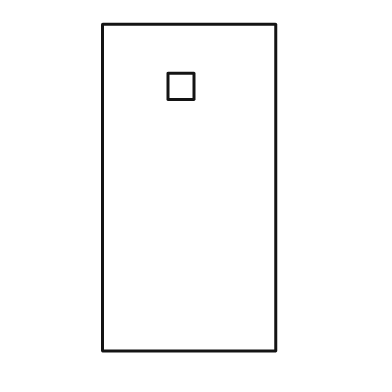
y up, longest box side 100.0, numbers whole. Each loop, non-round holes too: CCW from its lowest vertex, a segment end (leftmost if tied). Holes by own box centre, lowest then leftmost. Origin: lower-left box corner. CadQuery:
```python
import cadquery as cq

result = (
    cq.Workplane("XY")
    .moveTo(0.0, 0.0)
    .lineTo(53.0, 0.0)
    .lineTo(53.0, 100.0)
    .lineTo(0.0, 100.0)
    .close()
    .moveTo(20.0, 77.0)
    .lineTo(28.0, 77.0)
    .lineTo(28.0, 85.0)
    .lineTo(20.0, 85.0)
    .close()
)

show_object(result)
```